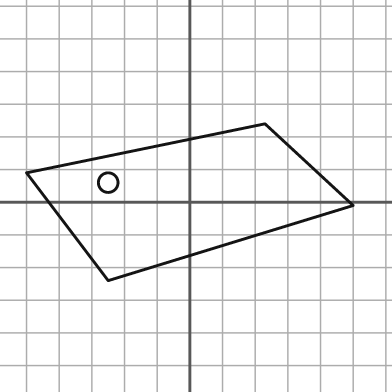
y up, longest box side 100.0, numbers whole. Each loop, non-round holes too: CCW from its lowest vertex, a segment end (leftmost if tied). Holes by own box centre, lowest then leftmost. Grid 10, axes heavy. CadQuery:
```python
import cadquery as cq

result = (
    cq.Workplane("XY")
    .moveTo(-25.0, -24.0)
    .lineTo(50.0, -1.0)
    .lineTo(23.0, 24.0)
    .lineTo(-50.0, 9.0)
    .close()
    .moveTo(-25.0, 6.0)
    .circle(3.0)
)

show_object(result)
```